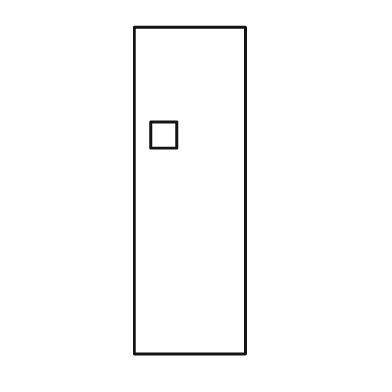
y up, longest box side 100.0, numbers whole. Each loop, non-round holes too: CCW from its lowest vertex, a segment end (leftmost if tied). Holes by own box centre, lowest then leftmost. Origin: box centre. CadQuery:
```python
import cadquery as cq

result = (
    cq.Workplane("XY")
    .moveTo(-17.0, -50.0)
    .lineTo(17.0, -50.0)
    .lineTo(17.0, 50.0)
    .lineTo(-17.0, 50.0)
    .close()
    .moveTo(-12.0, 13.0)
    .lineTo(-4.0, 13.0)
    .lineTo(-4.0, 21.0)
    .lineTo(-12.0, 21.0)
    .close()
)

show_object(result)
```